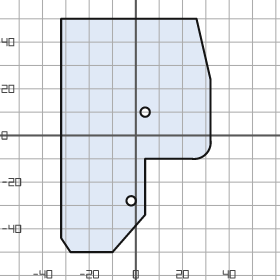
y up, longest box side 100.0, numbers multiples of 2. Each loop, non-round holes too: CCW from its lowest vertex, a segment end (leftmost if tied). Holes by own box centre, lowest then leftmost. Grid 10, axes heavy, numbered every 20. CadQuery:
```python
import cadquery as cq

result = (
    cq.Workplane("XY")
    .moveTo(-28.0, -50.0)
    .lineTo(-10.0, -50.0)
    .lineTo(4.0, -34.0)
    .lineTo(4.0, -10.0)
    .lineTo(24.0, -10.0)
    .threePointArc((30.0, -8.0), (32.0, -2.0))
    .lineTo(32.0, 24.0)
    .lineTo(26.0, 50.0)
    .lineTo(-32.0, 50.0)
    .lineTo(-32.0, -44.0)
    .close()
    .moveTo(-2.0, -28.0)
    .circle(2.0)
    .moveTo(4.0, 10.0)
    .circle(2.0)
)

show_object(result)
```